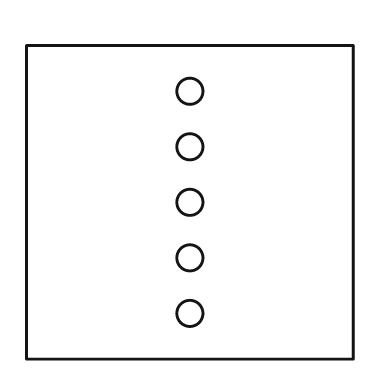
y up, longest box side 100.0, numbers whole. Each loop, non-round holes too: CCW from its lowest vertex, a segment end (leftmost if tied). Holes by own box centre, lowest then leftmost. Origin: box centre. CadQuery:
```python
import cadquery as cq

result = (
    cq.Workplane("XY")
    .moveTo(-50.0, -48.0)
    .lineTo(50.0, -48.0)
    .lineTo(50.0, 48.0)
    .lineTo(-50.0, 48.0)
    .close()
    .moveTo(0.0, -34.0)
    .circle(4.0)
    .moveTo(0.0, -17.0)
    .circle(4.0)
    .moveTo(0.0, 0.0)
    .circle(4.0)
    .moveTo(0.0, 17.0)
    .circle(4.0)
    .moveTo(0.0, 34.0)
    .circle(4.0)
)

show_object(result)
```